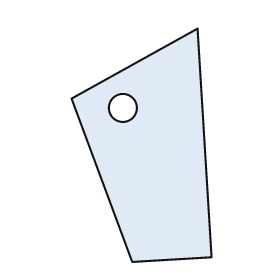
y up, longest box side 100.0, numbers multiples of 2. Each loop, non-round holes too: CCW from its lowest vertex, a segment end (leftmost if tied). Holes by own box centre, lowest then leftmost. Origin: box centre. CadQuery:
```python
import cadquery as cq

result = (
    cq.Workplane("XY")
    .moveTo(-4.0, -50.0)
    .lineTo(30.0, -48.0)
    .lineTo(24.0, 50.0)
    .lineTo(-30.0, 20.0)
    .close()
    .moveTo(-8.0, 16.0)
    .circle(6.0)
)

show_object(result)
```